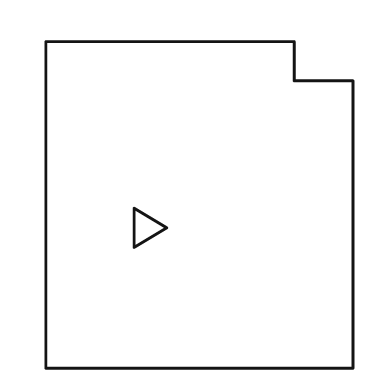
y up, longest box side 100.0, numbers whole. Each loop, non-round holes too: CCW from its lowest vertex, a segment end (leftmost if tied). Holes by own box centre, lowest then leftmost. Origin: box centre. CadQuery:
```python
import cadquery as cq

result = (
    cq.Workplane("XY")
    .moveTo(-47.0, -50.0)
    .lineTo(47.0, -50.0)
    .lineTo(47.0, 38.0)
    .lineTo(29.0, 38.0)
    .lineTo(29.0, 50.0)
    .lineTo(-47.0, 50.0)
    .close()
    .moveTo(-20.0, -13.0)
    .lineTo(-10.0, -7.0)
    .lineTo(-20.0, -1.0)
    .close()
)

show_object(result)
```